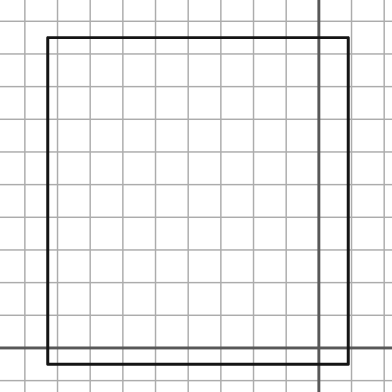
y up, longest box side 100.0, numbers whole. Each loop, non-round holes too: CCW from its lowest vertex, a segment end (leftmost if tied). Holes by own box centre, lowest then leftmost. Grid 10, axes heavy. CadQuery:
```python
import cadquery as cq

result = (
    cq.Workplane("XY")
    .moveTo(-83.0, -5.0)
    .lineTo(9.0, -5.0)
    .lineTo(9.0, 95.0)
    .lineTo(-83.0, 95.0)
    .close()
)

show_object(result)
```